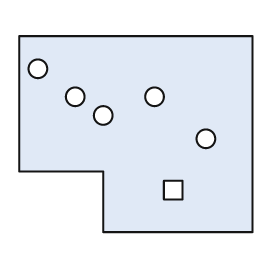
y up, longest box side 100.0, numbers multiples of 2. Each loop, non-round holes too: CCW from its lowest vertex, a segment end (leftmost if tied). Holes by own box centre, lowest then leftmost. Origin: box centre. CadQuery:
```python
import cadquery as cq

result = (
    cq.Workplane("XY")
    .moveTo(-14.0, -42.0)
    .lineTo(50.0, -42.0)
    .lineTo(50.0, 42.0)
    .lineTo(-50.0, 42.0)
    .lineTo(-50.0, -16.0)
    .lineTo(-14.0, -16.0)
    .close()
    .moveTo(12.0, -28.0)
    .lineTo(20.0, -28.0)
    .lineTo(20.0, -20.0)
    .lineTo(12.0, -20.0)
    .close()
    .moveTo(30.0, -2.0)
    .circle(4.0)
    .moveTo(-14.0, 8.0)
    .circle(4.0)
    .moveTo(-26.0, 16.0)
    .circle(4.0)
    .moveTo(8.0, 16.0)
    .circle(4.0)
    .moveTo(-42.0, 28.0)
    .circle(4.0)
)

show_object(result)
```